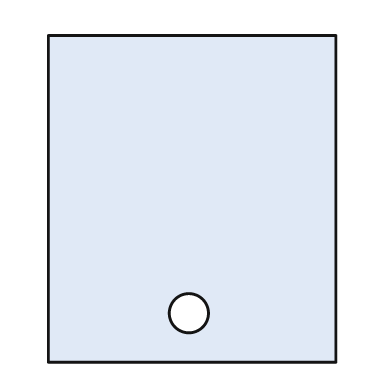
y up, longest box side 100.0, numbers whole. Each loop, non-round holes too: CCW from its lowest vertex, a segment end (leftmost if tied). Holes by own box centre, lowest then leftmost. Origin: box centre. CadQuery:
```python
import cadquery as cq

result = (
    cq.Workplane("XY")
    .moveTo(-44.0, -50.0)
    .lineTo(44.0, -50.0)
    .lineTo(44.0, 50.0)
    .lineTo(-44.0, 50.0)
    .close()
    .moveTo(-1.0, -35.0)
    .circle(6.0)
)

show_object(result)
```